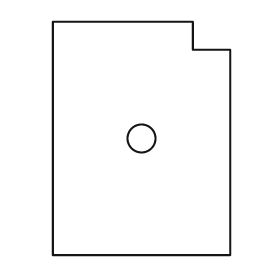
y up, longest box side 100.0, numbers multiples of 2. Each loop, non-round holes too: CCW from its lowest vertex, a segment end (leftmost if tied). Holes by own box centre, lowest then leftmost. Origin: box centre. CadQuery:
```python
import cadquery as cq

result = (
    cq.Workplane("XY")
    .moveTo(-38.0, -50.0)
    .lineTo(38.0, -50.0)
    .lineTo(38.0, 38.0)
    .lineTo(22.0, 38.0)
    .lineTo(22.0, 50.0)
    .lineTo(-38.0, 50.0)
    .close()
    .moveTo(0.0, 0.0)
    .circle(6.0)
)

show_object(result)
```